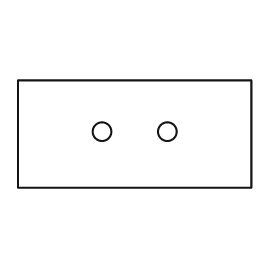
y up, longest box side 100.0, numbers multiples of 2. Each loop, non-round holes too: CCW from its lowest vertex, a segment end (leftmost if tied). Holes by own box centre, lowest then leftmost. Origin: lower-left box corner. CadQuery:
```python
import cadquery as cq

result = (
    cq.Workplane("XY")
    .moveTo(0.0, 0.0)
    .lineTo(100.0, 0.0)
    .lineTo(100.0, 46.0)
    .lineTo(0.0, 46.0)
    .close()
    .moveTo(36.0, 24.0)
    .circle(4.0)
    .moveTo(64.0, 24.0)
    .circle(4.0)
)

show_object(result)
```